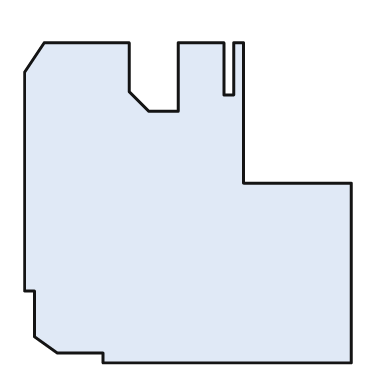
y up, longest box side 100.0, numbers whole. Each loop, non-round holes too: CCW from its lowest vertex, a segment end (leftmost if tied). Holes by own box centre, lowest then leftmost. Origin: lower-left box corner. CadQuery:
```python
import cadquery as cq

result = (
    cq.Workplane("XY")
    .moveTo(24.0, 0.0)
    .lineTo(100.0, 0.0)
    .lineTo(100.0, 55.0)
    .lineTo(67.0, 55.0)
    .lineTo(67.0, 98.0)
    .lineTo(64.0, 98.0)
    .lineTo(64.0, 82.0)
    .lineTo(61.0, 82.0)
    .lineTo(61.0, 98.0)
    .lineTo(47.0, 98.0)
    .lineTo(47.0, 77.0)
    .lineTo(38.0, 77.0)
    .lineTo(32.0, 83.0)
    .lineTo(32.0, 98.0)
    .lineTo(6.0, 98.0)
    .lineTo(0.0, 89.0)
    .lineTo(0.0, 22.0)
    .lineTo(3.0, 22.0)
    .lineTo(3.0, 8.0)
    .lineTo(10.0, 3.0)
    .lineTo(24.0, 3.0)
    .close()
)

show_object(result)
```